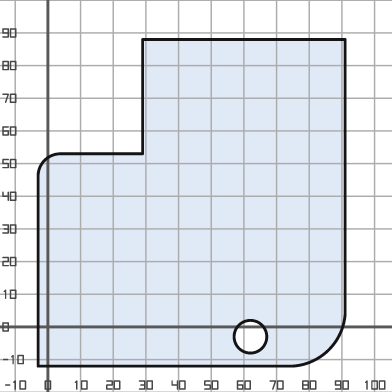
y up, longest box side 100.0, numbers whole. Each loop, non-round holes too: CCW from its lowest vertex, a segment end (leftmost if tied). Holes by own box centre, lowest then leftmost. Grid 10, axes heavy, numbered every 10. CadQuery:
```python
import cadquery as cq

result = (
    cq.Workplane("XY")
    .moveTo(-3.0, -12.0)
    .lineTo(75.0, -12.0)
    .threePointArc((86.0, -7.0), (91.0, 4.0))
    .lineTo(91.0, 88.0)
    .lineTo(29.0, 88.0)
    .lineTo(29.0, 53.0)
    .lineTo(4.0, 53.0)
    .threePointArc((-1.0, 51.0), (-3.0, 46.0))
    .close()
    .moveTo(62.0, -3.0)
    .circle(5.0)
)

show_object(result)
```